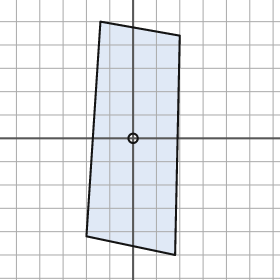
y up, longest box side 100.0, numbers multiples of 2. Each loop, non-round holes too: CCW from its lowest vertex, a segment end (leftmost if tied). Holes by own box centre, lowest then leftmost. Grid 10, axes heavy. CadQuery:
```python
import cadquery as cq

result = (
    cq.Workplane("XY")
    .moveTo(18.0, -50.0)
    .lineTo(20.0, 44.0)
    .lineTo(-14.0, 50.0)
    .lineTo(-20.0, -42.0)
    .close()
    .moveTo(0.0, 0.0)
    .circle(2.0)
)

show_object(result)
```